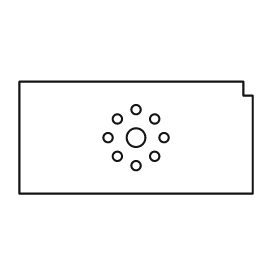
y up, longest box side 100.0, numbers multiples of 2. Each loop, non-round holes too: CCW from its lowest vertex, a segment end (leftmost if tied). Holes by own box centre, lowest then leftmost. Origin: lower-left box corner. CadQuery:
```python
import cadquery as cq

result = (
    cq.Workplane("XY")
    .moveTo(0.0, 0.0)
    .lineTo(100.0, 0.0)
    .lineTo(100.0, 42.0)
    .lineTo(96.0, 42.0)
    .lineTo(96.0, 48.0)
    .lineTo(0.0, 48.0)
    .close()
    .moveTo(50.0, 12.0)
    .circle(2.0)
    .moveTo(42.0, 16.0)
    .circle(2.0)
    .moveTo(58.0, 16.0)
    .circle(2.0)
    .moveTo(38.0, 24.0)
    .circle(2.0)
    .moveTo(50.0, 24.0)
    .circle(4.0)
    .moveTo(62.0, 24.0)
    .circle(2.0)
    .moveTo(42.0, 32.0)
    .circle(2.0)
    .moveTo(58.0, 32.0)
    .circle(2.0)
    .moveTo(50.0, 36.0)
    .circle(2.0)
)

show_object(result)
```